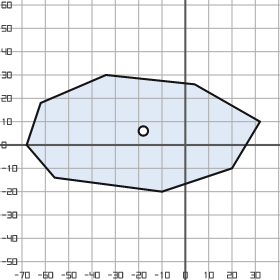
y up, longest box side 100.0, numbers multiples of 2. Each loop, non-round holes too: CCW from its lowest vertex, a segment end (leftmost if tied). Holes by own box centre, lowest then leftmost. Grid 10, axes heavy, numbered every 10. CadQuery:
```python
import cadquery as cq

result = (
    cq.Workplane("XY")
    .moveTo(-10.0, -20.0)
    .lineTo(20.0, -10.0)
    .lineTo(32.0, 10.0)
    .lineTo(4.0, 26.0)
    .lineTo(-34.0, 30.0)
    .lineTo(-62.0, 18.0)
    .lineTo(-68.0, 0.0)
    .lineTo(-56.0, -14.0)
    .close()
    .moveTo(-18.0, 6.0)
    .circle(2.0)
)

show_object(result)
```